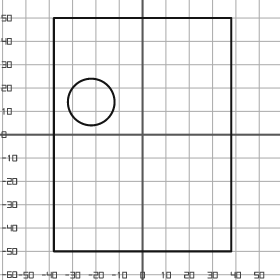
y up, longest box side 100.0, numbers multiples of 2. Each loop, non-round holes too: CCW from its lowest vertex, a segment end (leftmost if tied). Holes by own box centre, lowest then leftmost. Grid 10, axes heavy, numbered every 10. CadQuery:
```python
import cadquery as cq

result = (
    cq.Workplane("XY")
    .moveTo(-38.0, -50.0)
    .lineTo(38.0, -50.0)
    .lineTo(38.0, 50.0)
    .lineTo(-38.0, 50.0)
    .close()
    .moveTo(-22.0, 14.0)
    .circle(10.0)
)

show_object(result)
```